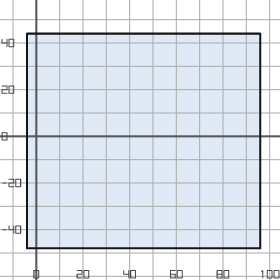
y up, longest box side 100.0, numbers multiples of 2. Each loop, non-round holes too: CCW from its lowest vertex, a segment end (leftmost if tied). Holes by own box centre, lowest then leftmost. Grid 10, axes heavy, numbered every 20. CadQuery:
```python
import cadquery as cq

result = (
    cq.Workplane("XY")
    .moveTo(-4.0, -48.0)
    .lineTo(96.0, -48.0)
    .lineTo(96.0, 44.0)
    .lineTo(-4.0, 44.0)
    .close()
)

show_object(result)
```